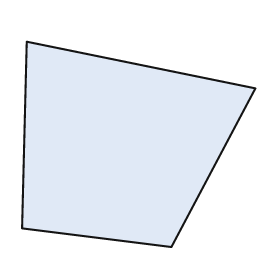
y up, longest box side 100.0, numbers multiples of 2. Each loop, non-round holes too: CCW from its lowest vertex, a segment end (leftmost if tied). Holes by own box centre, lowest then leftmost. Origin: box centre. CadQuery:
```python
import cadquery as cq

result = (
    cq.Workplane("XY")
    .moveTo(14.0, -44.0)
    .lineTo(50.0, 24.0)
    .lineTo(-48.0, 44.0)
    .lineTo(-50.0, -36.0)
    .close()
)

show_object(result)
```